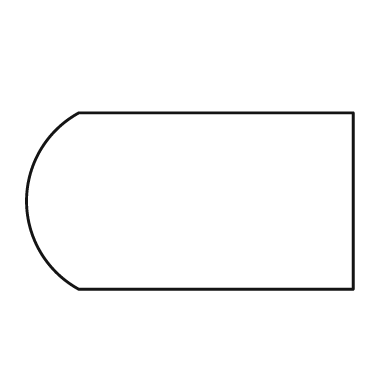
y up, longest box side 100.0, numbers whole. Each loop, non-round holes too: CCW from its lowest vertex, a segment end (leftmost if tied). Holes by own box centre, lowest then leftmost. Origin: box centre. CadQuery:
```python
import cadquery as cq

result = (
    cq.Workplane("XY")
    .moveTo(-34.0, -27.0)
    .lineTo(50.0, -27.0)
    .lineTo(50.0, 27.0)
    .lineTo(-34.0, 27.0)
    .threePointArc((-50.0, 0.0), (-34.0, -27.0))
    .close()
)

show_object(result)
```